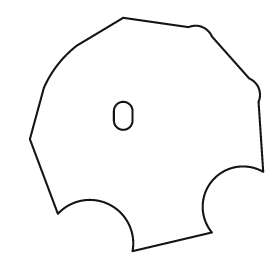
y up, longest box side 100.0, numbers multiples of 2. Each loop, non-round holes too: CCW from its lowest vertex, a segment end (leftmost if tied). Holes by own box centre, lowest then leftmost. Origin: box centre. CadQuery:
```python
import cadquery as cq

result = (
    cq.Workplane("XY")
    .moveTo(-6.0, -50.0)
    .lineTo(28.0, -42.0)
    .threePointArc((28.0, -20.0), (50.0, -16.0))
    .lineTo(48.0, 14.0)
    .threePointArc((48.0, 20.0), (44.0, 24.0))
    .lineTo(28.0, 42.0)
    .threePointArc((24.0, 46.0), (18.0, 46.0))
    .lineTo(-10.0, 50.0)
    .lineTo(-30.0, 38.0)
    .threePointArc((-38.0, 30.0), (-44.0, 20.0))
    .lineTo(-50.0, -2.0)
    .lineTo(-38.0, -34.0)
    .threePointArc((-16.0, -30.0), (-6.0, -50.0))
    .close()
    .moveTo(-14.0, 6.0)
    .threePointArc((-10.0, 2.0), (-6.0, 6.0))
    .lineTo(-6.0, 10.0)
    .threePointArc((-10.0, 14.0), (-14.0, 10.0))
    .close()
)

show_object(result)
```